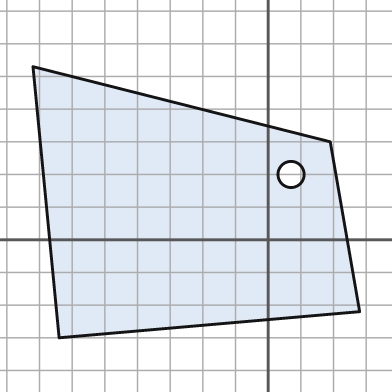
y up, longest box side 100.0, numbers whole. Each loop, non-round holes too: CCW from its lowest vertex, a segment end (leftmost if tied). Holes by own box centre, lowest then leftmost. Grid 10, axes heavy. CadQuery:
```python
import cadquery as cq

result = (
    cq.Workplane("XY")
    .moveTo(-64.0, -30.0)
    .lineTo(28.0, -22.0)
    .lineTo(19.0, 30.0)
    .lineTo(-72.0, 53.0)
    .close()
    .moveTo(7.0, 20.0)
    .circle(4.0)
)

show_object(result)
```